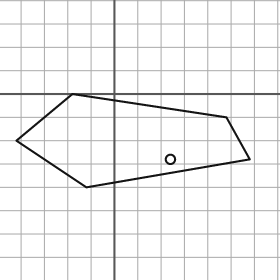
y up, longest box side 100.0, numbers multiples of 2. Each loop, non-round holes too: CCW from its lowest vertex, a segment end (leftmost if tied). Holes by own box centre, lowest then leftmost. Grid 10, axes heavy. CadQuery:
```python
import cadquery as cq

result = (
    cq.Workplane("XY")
    .moveTo(-12.0, -40.0)
    .lineTo(58.0, -28.0)
    .lineTo(48.0, -10.0)
    .lineTo(-18.0, 0.0)
    .lineTo(-42.0, -20.0)
    .close()
    .moveTo(24.0, -28.0)
    .circle(2.0)
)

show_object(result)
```